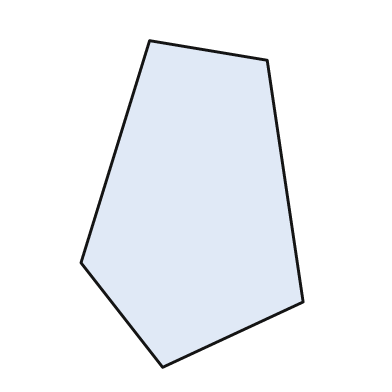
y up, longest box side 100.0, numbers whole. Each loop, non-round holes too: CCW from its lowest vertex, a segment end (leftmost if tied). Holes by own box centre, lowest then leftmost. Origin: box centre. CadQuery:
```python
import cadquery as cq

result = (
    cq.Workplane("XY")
    .moveTo(-9.0, -50.0)
    .lineTo(34.0, -30.0)
    .lineTo(23.0, 44.0)
    .lineTo(-13.0, 50.0)
    .lineTo(-34.0, -18.0)
    .close()
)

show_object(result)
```